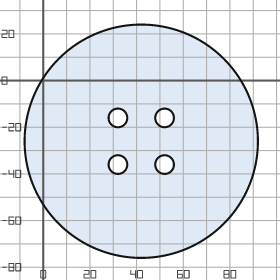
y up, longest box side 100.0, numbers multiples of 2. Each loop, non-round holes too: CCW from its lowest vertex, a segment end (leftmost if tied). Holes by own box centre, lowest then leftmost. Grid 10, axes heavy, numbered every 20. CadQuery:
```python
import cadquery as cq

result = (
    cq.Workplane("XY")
    .moveTo(42.0, -26.0)
    .circle(50.0)
    .moveTo(32.0, -36.0)
    .circle(4.0)
    .moveTo(52.0, -36.0)
    .circle(4.0)
    .moveTo(32.0, -16.0)
    .circle(4.0)
    .moveTo(52.0, -16.0)
    .circle(4.0)
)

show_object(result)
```